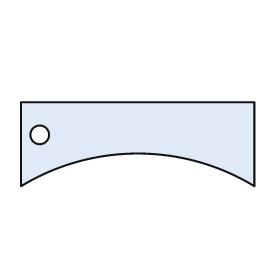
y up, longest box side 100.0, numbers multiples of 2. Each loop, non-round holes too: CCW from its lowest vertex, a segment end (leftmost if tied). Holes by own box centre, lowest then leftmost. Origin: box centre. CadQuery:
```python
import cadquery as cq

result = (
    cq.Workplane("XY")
    .moveTo(-50.0, -18.0)
    .threePointArc((0.0, -4.0), (50.0, -18.0))
    .lineTo(50.0, 18.0)
    .lineTo(-50.0, 18.0)
    .close()
    .moveTo(-42.0, 4.0)
    .circle(4.0)
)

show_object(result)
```